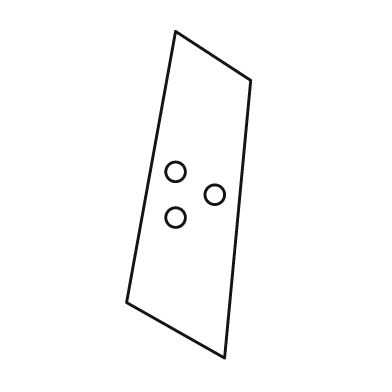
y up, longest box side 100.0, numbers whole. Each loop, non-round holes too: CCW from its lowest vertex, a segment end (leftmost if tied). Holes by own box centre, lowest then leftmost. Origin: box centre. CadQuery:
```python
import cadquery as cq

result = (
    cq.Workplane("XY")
    .moveTo(11.0, -50.0)
    .lineTo(19.0, 35.0)
    .lineTo(-4.0, 50.0)
    .lineTo(-19.0, -33.0)
    .close()
    .moveTo(-4.0, -7.0)
    .circle(3.0)
    .moveTo(8.0, 0.0)
    .circle(3.0)
    .moveTo(-4.0, 7.0)
    .circle(3.0)
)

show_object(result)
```